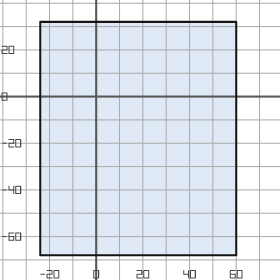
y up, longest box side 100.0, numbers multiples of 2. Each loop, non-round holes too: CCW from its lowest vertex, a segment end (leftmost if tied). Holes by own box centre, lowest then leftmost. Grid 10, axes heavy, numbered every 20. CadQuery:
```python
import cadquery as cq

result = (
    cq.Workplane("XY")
    .moveTo(-24.0, -68.0)
    .lineTo(60.0, -68.0)
    .lineTo(60.0, 32.0)
    .lineTo(-24.0, 32.0)
    .close()
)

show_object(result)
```